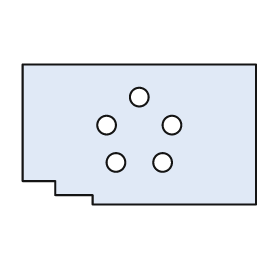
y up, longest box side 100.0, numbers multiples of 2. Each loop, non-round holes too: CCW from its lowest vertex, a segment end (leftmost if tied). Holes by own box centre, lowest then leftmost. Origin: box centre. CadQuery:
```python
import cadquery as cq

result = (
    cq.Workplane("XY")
    .moveTo(-20.0, -30.0)
    .lineTo(50.0, -30.0)
    .lineTo(50.0, 30.0)
    .lineTo(-50.0, 30.0)
    .lineTo(-50.0, -20.0)
    .lineTo(-36.0, -20.0)
    .lineTo(-36.0, -26.0)
    .lineTo(-20.0, -26.0)
    .close()
    .moveTo(-10.0, -12.0)
    .circle(4.0)
    .moveTo(10.0, -12.0)
    .circle(4.0)
    .moveTo(-14.0, 4.0)
    .circle(4.0)
    .moveTo(14.0, 4.0)
    .circle(4.0)
    .moveTo(0.0, 16.0)
    .circle(4.0)
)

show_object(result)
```